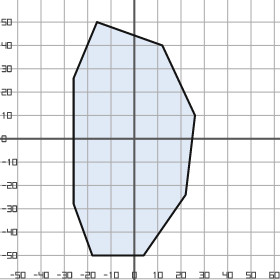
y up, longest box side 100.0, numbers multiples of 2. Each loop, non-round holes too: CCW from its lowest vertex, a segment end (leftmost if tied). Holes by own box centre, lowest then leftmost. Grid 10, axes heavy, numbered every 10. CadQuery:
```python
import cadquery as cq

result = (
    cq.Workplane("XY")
    .moveTo(-18.0, -50.0)
    .lineTo(4.0, -50.0)
    .lineTo(22.0, -24.0)
    .lineTo(26.0, 10.0)
    .lineTo(12.0, 40.0)
    .lineTo(-16.0, 50.0)
    .lineTo(-26.0, 26.0)
    .lineTo(-26.0, -28.0)
    .close()
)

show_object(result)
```